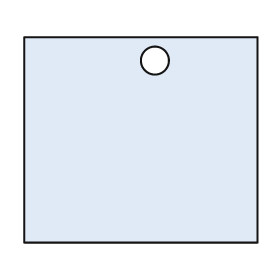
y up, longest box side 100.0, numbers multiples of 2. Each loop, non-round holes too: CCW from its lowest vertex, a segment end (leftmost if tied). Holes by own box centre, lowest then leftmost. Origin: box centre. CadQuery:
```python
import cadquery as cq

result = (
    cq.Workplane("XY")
    .moveTo(-50.0, -44.0)
    .lineTo(50.0, -44.0)
    .lineTo(50.0, 44.0)
    .lineTo(-50.0, 44.0)
    .close()
    .moveTo(6.0, 34.0)
    .circle(6.0)
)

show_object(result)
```